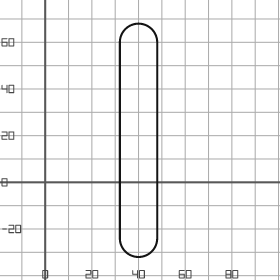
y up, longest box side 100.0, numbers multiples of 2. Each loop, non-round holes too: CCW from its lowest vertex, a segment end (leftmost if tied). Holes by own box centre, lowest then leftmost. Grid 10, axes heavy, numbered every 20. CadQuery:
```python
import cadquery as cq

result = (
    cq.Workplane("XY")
    .moveTo(32.0, -24.0)
    .threePointArc((40.0, -32.0), (48.0, -24.0))
    .lineTo(48.0, 60.0)
    .threePointArc((40.0, 68.0), (32.0, 60.0))
    .close()
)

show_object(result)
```